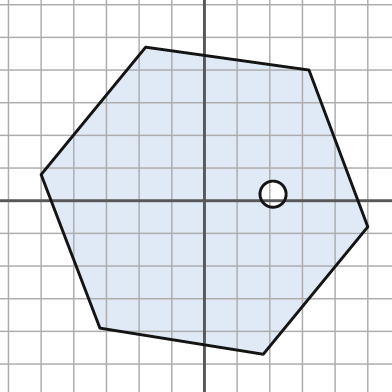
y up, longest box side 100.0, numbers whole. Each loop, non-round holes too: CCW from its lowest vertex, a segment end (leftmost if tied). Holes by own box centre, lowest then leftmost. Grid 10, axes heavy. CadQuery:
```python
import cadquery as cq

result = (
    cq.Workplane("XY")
    .moveTo(18.0, -47.0)
    .lineTo(50.0, -8.0)
    .lineTo(32.0, 40.0)
    .lineTo(-18.0, 47.0)
    .lineTo(-50.0, 8.0)
    .lineTo(-32.0, -39.0)
    .close()
    .moveTo(21.0, 2.0)
    .circle(4.0)
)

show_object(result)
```